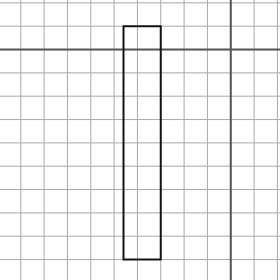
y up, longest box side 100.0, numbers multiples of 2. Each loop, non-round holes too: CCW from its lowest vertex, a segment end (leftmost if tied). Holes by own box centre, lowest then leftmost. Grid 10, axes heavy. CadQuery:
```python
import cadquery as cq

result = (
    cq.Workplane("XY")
    .moveTo(-46.0, -90.0)
    .lineTo(-30.0, -90.0)
    .lineTo(-30.0, 10.0)
    .lineTo(-46.0, 10.0)
    .close()
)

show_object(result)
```